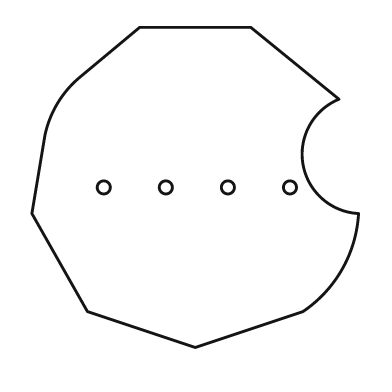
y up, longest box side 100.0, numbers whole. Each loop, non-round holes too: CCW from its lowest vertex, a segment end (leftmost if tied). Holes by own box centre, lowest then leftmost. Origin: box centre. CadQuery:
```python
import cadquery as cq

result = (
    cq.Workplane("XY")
    .moveTo(0.0, -49.0)
    .lineTo(33.0, -38.0)
    .threePointArc((45.0, -25.0), (50.0, -8.0))
    .threePointArc((33.0, 7.0), (44.0, 27.0))
    .lineTo(17.0, 49.0)
    .lineTo(-17.0, 49.0)
    .lineTo(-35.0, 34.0)
    .threePointArc((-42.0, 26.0), (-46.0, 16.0))
    .lineTo(-50.0, -8.0)
    .lineTo(-33.0, -38.0)
    .close()
    .moveTo(-28.0, 0.0)
    .circle(2.0)
    .moveTo(-9.0, 0.0)
    .circle(2.0)
    .moveTo(10.0, 0.0)
    .circle(2.0)
    .moveTo(29.0, 0.0)
    .circle(2.0)
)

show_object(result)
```